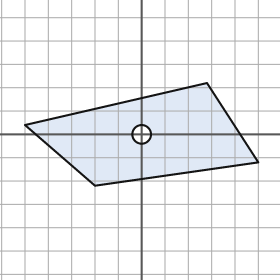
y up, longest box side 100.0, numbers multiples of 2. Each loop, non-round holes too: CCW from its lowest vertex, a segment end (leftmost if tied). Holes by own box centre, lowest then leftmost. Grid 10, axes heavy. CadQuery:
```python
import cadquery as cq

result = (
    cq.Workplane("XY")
    .moveTo(-20.0, -22.0)
    .lineTo(50.0, -12.0)
    .lineTo(28.0, 22.0)
    .lineTo(-50.0, 4.0)
    .close()
    .moveTo(0.0, 0.0)
    .circle(4.0)
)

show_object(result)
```